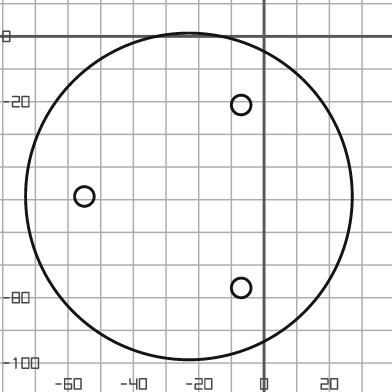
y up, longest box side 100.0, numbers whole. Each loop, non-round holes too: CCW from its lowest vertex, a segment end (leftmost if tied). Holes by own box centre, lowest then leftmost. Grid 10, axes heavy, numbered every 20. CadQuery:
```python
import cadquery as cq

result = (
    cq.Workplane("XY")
    .moveTo(-23.0, -49.0)
    .circle(50.0)
    .moveTo(-7.0, -77.0)
    .circle(3.0)
    .moveTo(-55.0, -49.0)
    .circle(3.0)
    .moveTo(-7.0, -21.0)
    .circle(3.0)
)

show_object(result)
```